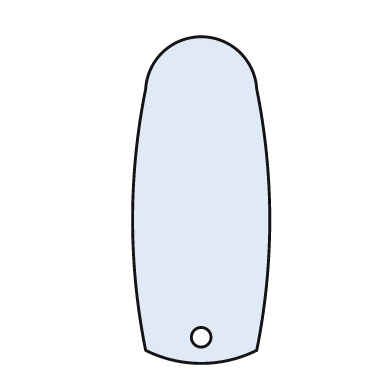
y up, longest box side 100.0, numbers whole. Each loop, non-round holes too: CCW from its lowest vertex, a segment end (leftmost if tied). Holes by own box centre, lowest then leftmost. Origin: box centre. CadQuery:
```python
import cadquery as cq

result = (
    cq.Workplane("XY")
    .moveTo(-17.0, -46.0)
    .threePointArc((0.0, -50.0), (17.0, -46.0))
    .threePointArc((21.0, -6.0), (17.0, 34.0))
    .threePointArc((0.0, 50.0), (-17.0, 34.0))
    .threePointArc((-21.0, -6.0), (-17.0, -46.0))
    .close()
    .moveTo(0.0, -42.0)
    .circle(3.0)
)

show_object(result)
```